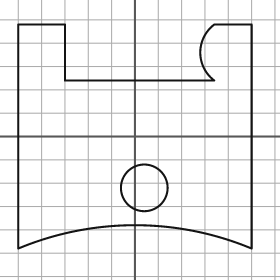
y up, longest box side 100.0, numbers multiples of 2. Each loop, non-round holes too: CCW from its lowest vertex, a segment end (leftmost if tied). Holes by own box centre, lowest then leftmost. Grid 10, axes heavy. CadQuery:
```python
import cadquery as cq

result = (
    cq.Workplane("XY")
    .moveTo(-50.0, -48.0)
    .threePointArc((0.0, -38.0), (50.0, -48.0))
    .lineTo(50.0, 48.0)
    .lineTo(34.0, 48.0)
    .threePointArc((28.0, 36.0), (34.0, 24.0))
    .lineTo(-30.0, 24.0)
    .lineTo(-30.0, 48.0)
    .lineTo(-50.0, 48.0)
    .close()
    .moveTo(4.0, -22.0)
    .circle(10.0)
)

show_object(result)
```